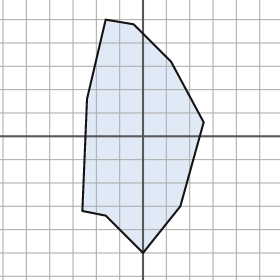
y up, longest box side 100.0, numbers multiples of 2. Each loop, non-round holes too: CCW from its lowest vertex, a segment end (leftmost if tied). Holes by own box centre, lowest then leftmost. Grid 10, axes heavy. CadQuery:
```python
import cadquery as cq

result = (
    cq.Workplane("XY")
    .moveTo(0.0, -50.0)
    .lineTo(16.0, -30.0)
    .lineTo(26.0, 6.0)
    .lineTo(12.0, 32.0)
    .lineTo(-4.0, 48.0)
    .lineTo(-16.0, 50.0)
    .lineTo(-24.0, 16.0)
    .lineTo(-26.0, -32.0)
    .lineTo(-16.0, -34.0)
    .close()
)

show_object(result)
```